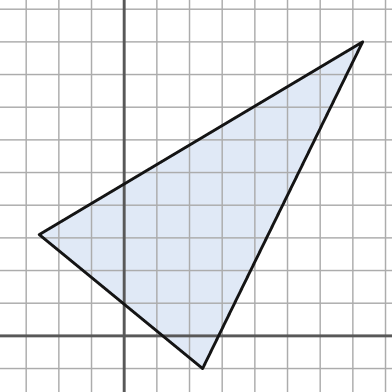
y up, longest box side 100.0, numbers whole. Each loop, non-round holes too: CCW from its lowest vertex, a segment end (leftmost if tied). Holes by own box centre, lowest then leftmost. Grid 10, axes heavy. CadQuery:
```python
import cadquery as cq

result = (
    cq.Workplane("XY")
    .moveTo(24.0, -10.0)
    .lineTo(73.0, 90.0)
    .lineTo(-26.0, 31.0)
    .close()
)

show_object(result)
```